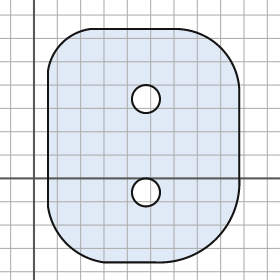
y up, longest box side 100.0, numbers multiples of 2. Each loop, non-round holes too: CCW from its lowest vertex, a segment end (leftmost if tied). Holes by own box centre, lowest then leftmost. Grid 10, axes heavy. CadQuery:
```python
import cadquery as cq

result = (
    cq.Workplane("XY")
    .moveTo(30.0, -36.0)
    .lineTo(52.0, -36.0)
    .threePointArc((78.0, -26.0), (88.0, 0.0))
    .lineTo(88.0, 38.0)
    .threePointArc((80.0, 56.0), (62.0, 64.0))
    .lineTo(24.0, 64.0)
    .threePointArc((12.0, 58.0), (6.0, 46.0))
    .lineTo(6.0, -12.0)
    .threePointArc((14.0, -28.0), (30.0, -36.0))
    .close()
    .moveTo(48.0, -6.0)
    .circle(6.0)
    .moveTo(48.0, 34.0)
    .circle(6.0)
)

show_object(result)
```